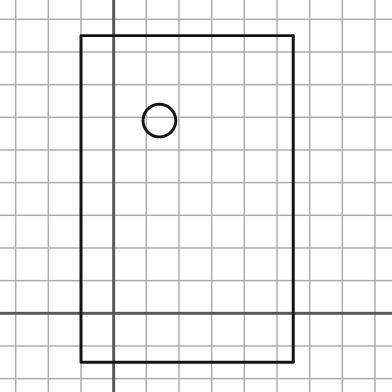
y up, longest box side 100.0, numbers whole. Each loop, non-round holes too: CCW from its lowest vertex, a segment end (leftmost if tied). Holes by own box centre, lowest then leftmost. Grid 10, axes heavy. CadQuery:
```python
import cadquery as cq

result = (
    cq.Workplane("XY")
    .moveTo(-10.0, -15.0)
    .lineTo(55.0, -15.0)
    .lineTo(55.0, 85.0)
    .lineTo(-10.0, 85.0)
    .close()
    .moveTo(14.0, 59.0)
    .circle(5.0)
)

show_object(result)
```